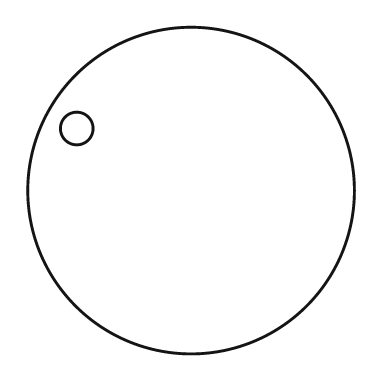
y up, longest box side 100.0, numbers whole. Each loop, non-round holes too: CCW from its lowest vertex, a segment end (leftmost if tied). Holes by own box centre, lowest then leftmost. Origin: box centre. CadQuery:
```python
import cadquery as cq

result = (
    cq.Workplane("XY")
    .moveTo(0.0, 0.0)
    .circle(50.0)
    .moveTo(-35.0, 19.0)
    .circle(5.0)
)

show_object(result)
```